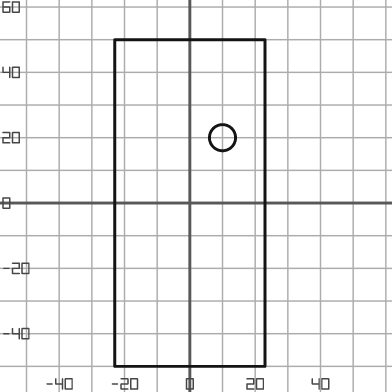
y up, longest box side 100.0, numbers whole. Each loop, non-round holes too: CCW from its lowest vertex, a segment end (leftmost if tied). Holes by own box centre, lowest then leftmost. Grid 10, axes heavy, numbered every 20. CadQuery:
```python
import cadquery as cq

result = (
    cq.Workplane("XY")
    .moveTo(-23.0, -50.0)
    .lineTo(23.0, -50.0)
    .lineTo(23.0, 50.0)
    .lineTo(-23.0, 50.0)
    .close()
    .moveTo(10.0, 20.0)
    .circle(4.0)
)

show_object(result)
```